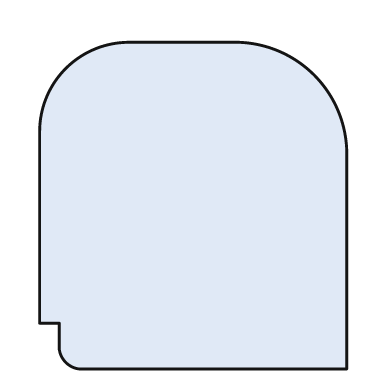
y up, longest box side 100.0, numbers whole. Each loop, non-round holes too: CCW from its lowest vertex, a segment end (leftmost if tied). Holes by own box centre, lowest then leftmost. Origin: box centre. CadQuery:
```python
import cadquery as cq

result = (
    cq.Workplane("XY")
    .moveTo(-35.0, -50.0)
    .lineTo(47.0, -50.0)
    .lineTo(47.0, 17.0)
    .threePointArc((37.0, 40.0), (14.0, 50.0))
    .lineTo(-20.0, 50.0)
    .threePointArc((-39.0, 42.0), (-47.0, 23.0))
    .lineTo(-47.0, -36.0)
    .lineTo(-41.0, -36.0)
    .lineTo(-41.0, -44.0)
    .threePointArc((-39.0, -48.0), (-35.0, -50.0))
    .close()
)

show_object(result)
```